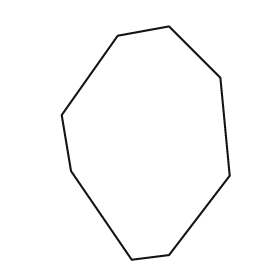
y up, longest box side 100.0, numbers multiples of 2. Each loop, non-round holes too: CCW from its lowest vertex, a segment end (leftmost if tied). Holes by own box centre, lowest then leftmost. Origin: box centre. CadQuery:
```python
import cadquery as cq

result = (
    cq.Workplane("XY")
    .moveTo(-6.0, -50.0)
    .lineTo(10.0, -48.0)
    .lineTo(36.0, -14.0)
    .lineTo(32.0, 28.0)
    .lineTo(10.0, 50.0)
    .lineTo(-12.0, 46.0)
    .lineTo(-36.0, 12.0)
    .lineTo(-32.0, -12.0)
    .close()
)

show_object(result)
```